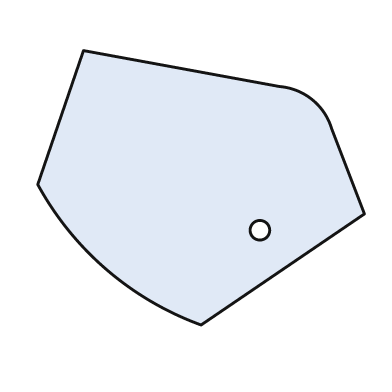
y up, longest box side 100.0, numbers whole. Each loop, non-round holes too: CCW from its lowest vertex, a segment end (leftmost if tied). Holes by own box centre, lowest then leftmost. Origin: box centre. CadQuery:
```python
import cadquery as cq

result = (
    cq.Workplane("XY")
    .moveTo(0.0, -42.0)
    .lineTo(50.0, -8.0)
    .lineTo(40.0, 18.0)
    .threePointArc((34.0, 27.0), (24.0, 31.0))
    .lineTo(-36.0, 42.0)
    .lineTo(-50.0, 1.0)
    .threePointArc((-29.0, -25.0), (0.0, -42.0))
    .close()
    .moveTo(18.0, -13.0)
    .circle(3.0)
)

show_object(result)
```